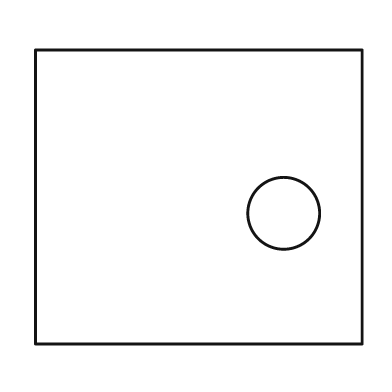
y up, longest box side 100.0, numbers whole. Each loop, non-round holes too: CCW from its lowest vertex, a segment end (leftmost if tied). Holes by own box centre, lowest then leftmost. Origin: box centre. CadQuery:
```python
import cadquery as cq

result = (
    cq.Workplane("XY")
    .moveTo(-50.0, -45.0)
    .lineTo(50.0, -45.0)
    .lineTo(50.0, 45.0)
    .lineTo(-50.0, 45.0)
    .close()
    .moveTo(26.0, -5.0)
    .circle(11.0)
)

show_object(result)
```